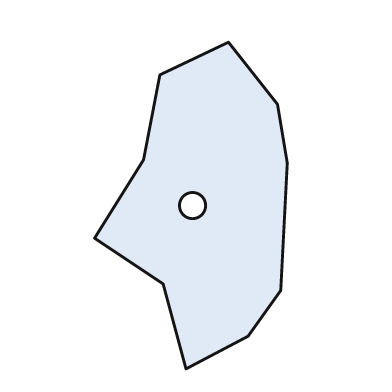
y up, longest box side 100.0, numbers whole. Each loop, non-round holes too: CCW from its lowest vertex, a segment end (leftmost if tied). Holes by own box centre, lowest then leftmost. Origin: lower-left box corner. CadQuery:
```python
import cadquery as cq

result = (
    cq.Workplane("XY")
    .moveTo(28.0, 0.0)
    .lineTo(47.0, 10.0)
    .lineTo(57.0, 24.0)
    .lineTo(59.0, 63.0)
    .lineTo(56.0, 81.0)
    .lineTo(41.0, 100.0)
    .lineTo(20.0, 90.0)
    .lineTo(15.0, 64.0)
    .lineTo(0.0, 40.0)
    .lineTo(21.0, 26.0)
    .close()
    .moveTo(30.0, 50.0)
    .circle(4.0)
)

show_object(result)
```